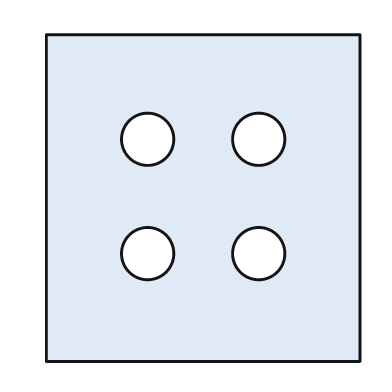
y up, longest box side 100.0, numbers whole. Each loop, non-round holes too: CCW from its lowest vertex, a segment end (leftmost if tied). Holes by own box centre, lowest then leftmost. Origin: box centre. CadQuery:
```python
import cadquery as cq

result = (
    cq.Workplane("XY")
    .moveTo(-48.0, -50.0)
    .lineTo(48.0, -50.0)
    .lineTo(48.0, 50.0)
    .lineTo(-48.0, 50.0)
    .close()
    .moveTo(-17.0, -17.0)
    .circle(8.0)
    .moveTo(17.0, -17.0)
    .circle(8.0)
    .moveTo(-17.0, 18.0)
    .circle(8.0)
    .moveTo(17.0, 18.0)
    .circle(8.0)
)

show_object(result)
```